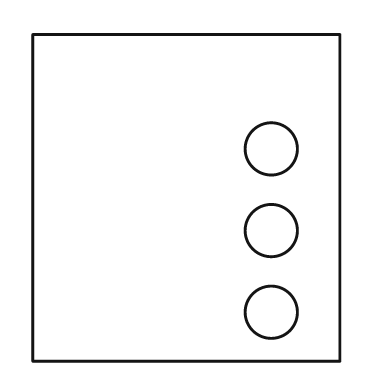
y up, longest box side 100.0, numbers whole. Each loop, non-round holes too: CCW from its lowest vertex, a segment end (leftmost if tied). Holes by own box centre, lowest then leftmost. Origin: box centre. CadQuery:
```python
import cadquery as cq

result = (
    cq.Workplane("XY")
    .moveTo(-47.0, -50.0)
    .lineTo(47.0, -50.0)
    .lineTo(47.0, 50.0)
    .lineTo(-47.0, 50.0)
    .close()
    .moveTo(26.0, -35.0)
    .circle(8.0)
    .moveTo(26.0, -10.0)
    .circle(8.0)
    .moveTo(26.0, 15.0)
    .circle(8.0)
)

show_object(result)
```